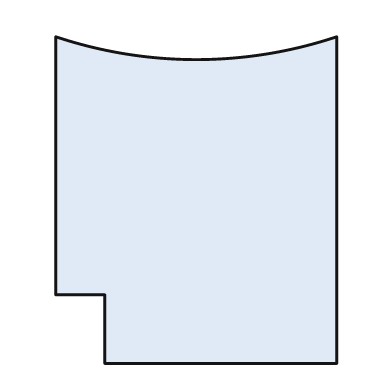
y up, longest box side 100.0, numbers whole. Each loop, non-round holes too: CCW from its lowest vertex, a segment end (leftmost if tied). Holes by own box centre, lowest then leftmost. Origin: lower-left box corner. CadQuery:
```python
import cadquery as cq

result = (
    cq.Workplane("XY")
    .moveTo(15.0, 0.0)
    .lineTo(86.0, 0.0)
    .lineTo(86.0, 100.0)
    .threePointArc((43.0, 93.0), (0.0, 100.0))
    .lineTo(0.0, 21.0)
    .lineTo(15.0, 21.0)
    .close()
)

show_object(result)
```